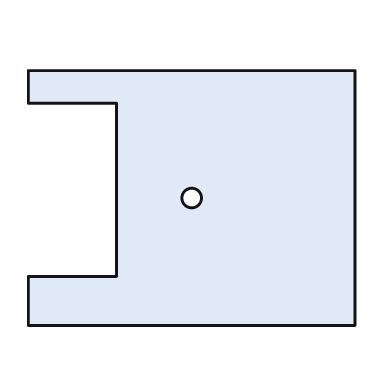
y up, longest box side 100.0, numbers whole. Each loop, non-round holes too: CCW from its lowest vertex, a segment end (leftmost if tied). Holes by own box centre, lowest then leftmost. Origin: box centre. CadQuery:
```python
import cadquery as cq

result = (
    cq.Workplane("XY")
    .moveTo(-50.0, -39.0)
    .lineTo(50.0, -39.0)
    .lineTo(50.0, 39.0)
    .lineTo(-50.0, 39.0)
    .lineTo(-50.0, 29.0)
    .lineTo(-23.0, 29.0)
    .lineTo(-23.0, -24.0)
    .lineTo(-50.0, -24.0)
    .close()
    .moveTo(0.0, 0.0)
    .circle(3.0)
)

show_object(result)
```